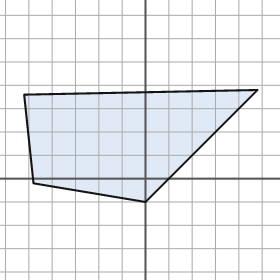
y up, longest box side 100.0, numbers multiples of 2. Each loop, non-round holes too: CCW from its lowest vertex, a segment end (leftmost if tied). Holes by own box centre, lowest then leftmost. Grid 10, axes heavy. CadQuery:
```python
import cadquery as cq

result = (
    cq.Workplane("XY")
    .moveTo(0.0, -10.0)
    .lineTo(48.0, 38.0)
    .lineTo(-52.0, 36.0)
    .lineTo(-48.0, -2.0)
    .close()
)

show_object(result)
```